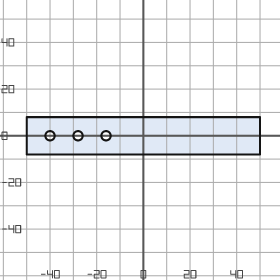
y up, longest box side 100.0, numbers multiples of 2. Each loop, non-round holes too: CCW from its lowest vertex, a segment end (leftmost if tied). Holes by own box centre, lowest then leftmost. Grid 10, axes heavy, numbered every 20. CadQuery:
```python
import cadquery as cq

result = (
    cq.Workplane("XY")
    .moveTo(-50.0, -8.0)
    .lineTo(50.0, -8.0)
    .lineTo(50.0, 8.0)
    .lineTo(-50.0, 8.0)
    .close()
    .moveTo(-40.0, 0.0)
    .circle(2.0)
    .moveTo(-28.0, 0.0)
    .circle(2.0)
    .moveTo(-16.0, 0.0)
    .circle(2.0)
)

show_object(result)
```